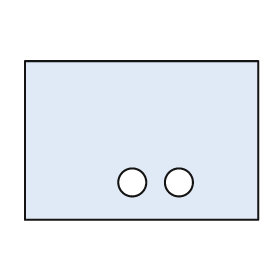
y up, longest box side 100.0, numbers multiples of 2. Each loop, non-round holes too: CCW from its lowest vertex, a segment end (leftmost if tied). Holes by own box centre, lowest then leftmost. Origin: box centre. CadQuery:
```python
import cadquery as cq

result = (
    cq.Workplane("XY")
    .moveTo(-50.0, -34.0)
    .lineTo(50.0, -34.0)
    .lineTo(50.0, 34.0)
    .lineTo(-50.0, 34.0)
    .close()
    .moveTo(-4.0, -18.0)
    .circle(6.0)
    .moveTo(16.0, -18.0)
    .circle(6.0)
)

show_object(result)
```